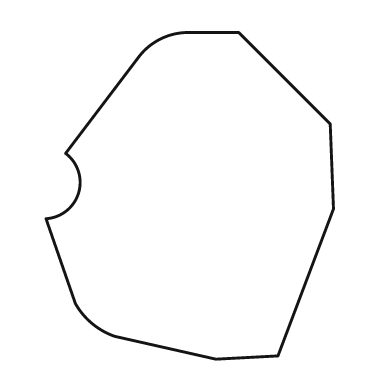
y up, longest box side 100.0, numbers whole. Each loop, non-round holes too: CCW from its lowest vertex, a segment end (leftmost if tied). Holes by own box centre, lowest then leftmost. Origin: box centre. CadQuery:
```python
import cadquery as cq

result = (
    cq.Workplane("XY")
    .moveTo(8.0, -50.0)
    .lineTo(27.0, -49.0)
    .lineTo(44.0, -4.0)
    .lineTo(43.0, 22.0)
    .lineTo(15.0, 50.0)
    .lineTo(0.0, 50.0)
    .threePointArc((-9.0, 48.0), (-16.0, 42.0))
    .lineTo(-38.0, 13.0)
    .threePointArc((-34.0, 1.0), (-44.0, -7.0))
    .lineTo(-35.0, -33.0)
    .threePointArc((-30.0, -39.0), (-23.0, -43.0))
    .close()
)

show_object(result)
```